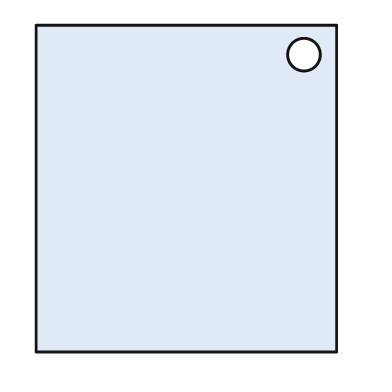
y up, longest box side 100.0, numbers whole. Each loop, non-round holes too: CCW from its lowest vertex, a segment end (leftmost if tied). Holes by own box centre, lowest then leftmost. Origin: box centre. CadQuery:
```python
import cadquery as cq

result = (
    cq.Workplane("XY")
    .moveTo(-46.0, -50.0)
    .lineTo(46.0, -50.0)
    .lineTo(46.0, 50.0)
    .lineTo(-46.0, 50.0)
    .close()
    .moveTo(36.0, 41.0)
    .circle(5.0)
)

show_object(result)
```